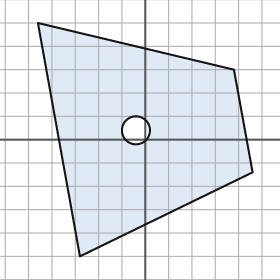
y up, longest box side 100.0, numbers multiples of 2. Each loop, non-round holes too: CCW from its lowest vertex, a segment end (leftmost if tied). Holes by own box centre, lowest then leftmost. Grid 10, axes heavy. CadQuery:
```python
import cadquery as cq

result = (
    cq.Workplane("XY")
    .moveTo(-28.0, -50.0)
    .lineTo(46.0, -14.0)
    .lineTo(38.0, 30.0)
    .lineTo(-46.0, 50.0)
    .close()
    .moveTo(-4.0, 4.0)
    .circle(6.0)
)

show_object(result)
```